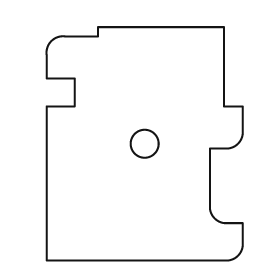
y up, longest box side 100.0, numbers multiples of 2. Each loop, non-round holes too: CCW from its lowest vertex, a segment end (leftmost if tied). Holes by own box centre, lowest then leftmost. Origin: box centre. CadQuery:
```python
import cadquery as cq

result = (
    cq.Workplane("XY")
    .moveTo(-42.0, -50.0)
    .lineTo(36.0, -50.0)
    .threePointArc((40.0, -48.0), (42.0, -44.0))
    .lineTo(42.0, -34.0)
    .lineTo(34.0, -34.0)
    .threePointArc((30.0, -32.0), (28.0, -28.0))
    .lineTo(28.0, -2.0)
    .lineTo(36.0, -2.0)
    .threePointArc((40.0, 0.0), (42.0, 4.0))
    .lineTo(42.0, 16.0)
    .lineTo(34.0, 16.0)
    .lineTo(34.0, 50.0)
    .lineTo(-20.0, 50.0)
    .lineTo(-20.0, 46.0)
    .lineTo(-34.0, 46.0)
    .threePointArc((-40.0, 44.0), (-42.0, 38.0))
    .lineTo(-42.0, 28.0)
    .lineTo(-30.0, 28.0)
    .lineTo(-30.0, 16.0)
    .lineTo(-42.0, 16.0)
    .close()
    .moveTo(0.0, 0.0)
    .circle(6.0)
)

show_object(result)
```